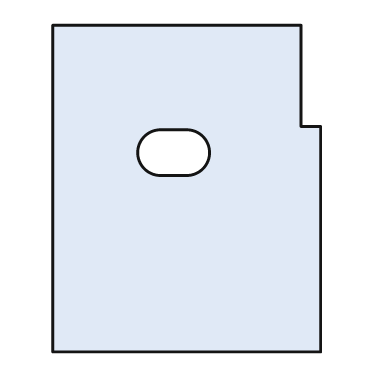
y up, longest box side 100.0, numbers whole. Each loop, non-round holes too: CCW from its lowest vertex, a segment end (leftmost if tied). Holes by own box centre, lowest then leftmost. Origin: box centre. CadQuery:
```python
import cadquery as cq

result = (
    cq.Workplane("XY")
    .moveTo(-41.0, -50.0)
    .lineTo(41.0, -50.0)
    .lineTo(41.0, 19.0)
    .lineTo(35.0, 19.0)
    .lineTo(35.0, 50.0)
    .lineTo(-41.0, 50.0)
    .close()
    .moveTo(-8.0, 4.0)
    .lineTo(0.0, 4.0)
    .threePointArc((7.0, 11.0), (0.0, 18.0))
    .lineTo(-8.0, 18.0)
    .threePointArc((-15.0, 11.0), (-8.0, 4.0))
    .close()
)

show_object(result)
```